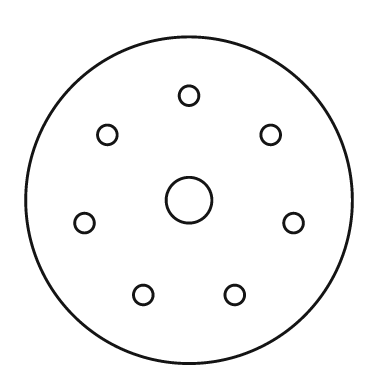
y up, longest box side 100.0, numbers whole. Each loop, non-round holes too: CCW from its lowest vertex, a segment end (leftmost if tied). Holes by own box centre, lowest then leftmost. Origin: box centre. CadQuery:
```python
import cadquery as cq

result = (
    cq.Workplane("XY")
    .moveTo(0.0, 0.0)
    .circle(50.0)
    .moveTo(-14.0, -29.0)
    .circle(3.0)
    .moveTo(14.0, -29.0)
    .circle(3.0)
    .moveTo(-32.0, -7.0)
    .circle(3.0)
    .moveTo(32.0, -7.0)
    .circle(3.0)
    .moveTo(0.0, 0.0)
    .circle(7.0)
    .moveTo(-25.0, 20.0)
    .circle(3.0)
    .moveTo(25.0, 20.0)
    .circle(3.0)
    .moveTo(0.0, 32.0)
    .circle(3.0)
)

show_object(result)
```